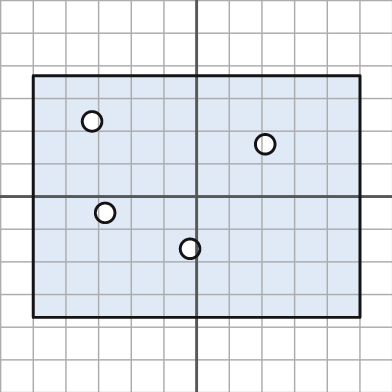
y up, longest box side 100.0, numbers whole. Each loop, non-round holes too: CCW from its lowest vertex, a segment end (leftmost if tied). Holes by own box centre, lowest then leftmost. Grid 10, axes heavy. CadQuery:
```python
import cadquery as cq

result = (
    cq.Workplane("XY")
    .moveTo(-50.0, -37.0)
    .lineTo(50.0, -37.0)
    .lineTo(50.0, 37.0)
    .lineTo(-50.0, 37.0)
    .close()
    .moveTo(-2.0, -16.0)
    .circle(3.0)
    .moveTo(-28.0, -5.0)
    .circle(3.0)
    .moveTo(21.0, 16.0)
    .circle(3.0)
    .moveTo(-32.0, 23.0)
    .circle(3.0)
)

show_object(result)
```